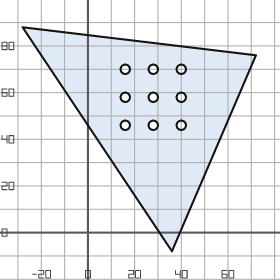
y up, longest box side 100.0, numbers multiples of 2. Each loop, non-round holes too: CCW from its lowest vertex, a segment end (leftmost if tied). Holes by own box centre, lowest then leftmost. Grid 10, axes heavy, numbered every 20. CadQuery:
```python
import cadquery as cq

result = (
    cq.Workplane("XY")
    .moveTo(36.0, -8.0)
    .lineTo(72.0, 76.0)
    .lineTo(-28.0, 88.0)
    .close()
    .moveTo(16.0, 46.0)
    .circle(2.0)
    .moveTo(28.0, 46.0)
    .circle(2.0)
    .moveTo(40.0, 46.0)
    .circle(2.0)
    .moveTo(16.0, 58.0)
    .circle(2.0)
    .moveTo(28.0, 58.0)
    .circle(2.0)
    .moveTo(40.0, 58.0)
    .circle(2.0)
    .moveTo(16.0, 70.0)
    .circle(2.0)
    .moveTo(28.0, 70.0)
    .circle(2.0)
    .moveTo(40.0, 70.0)
    .circle(2.0)
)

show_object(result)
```